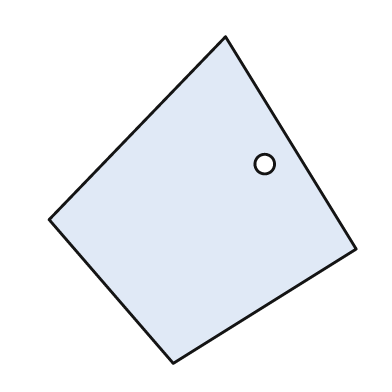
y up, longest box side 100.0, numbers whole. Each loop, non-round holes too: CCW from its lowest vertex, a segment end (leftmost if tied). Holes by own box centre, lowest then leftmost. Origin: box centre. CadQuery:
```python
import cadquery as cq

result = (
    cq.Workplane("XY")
    .moveTo(-9.0, -50.0)
    .lineTo(47.0, -15.0)
    .lineTo(7.0, 50.0)
    .lineTo(-47.0, -6.0)
    .close()
    .moveTo(19.0, 11.0)
    .circle(3.0)
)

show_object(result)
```